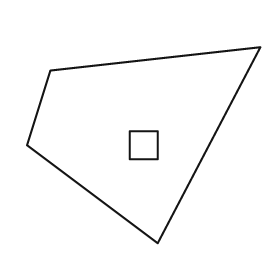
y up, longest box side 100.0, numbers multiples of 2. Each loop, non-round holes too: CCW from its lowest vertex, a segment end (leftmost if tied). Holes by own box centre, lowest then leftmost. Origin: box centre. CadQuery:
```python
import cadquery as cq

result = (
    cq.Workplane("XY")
    .moveTo(6.0, -42.0)
    .lineTo(50.0, 42.0)
    .lineTo(-40.0, 32.0)
    .lineTo(-50.0, 0.0)
    .close()
    .moveTo(-6.0, -6.0)
    .lineTo(6.0, -6.0)
    .lineTo(6.0, 6.0)
    .lineTo(-6.0, 6.0)
    .close()
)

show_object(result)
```